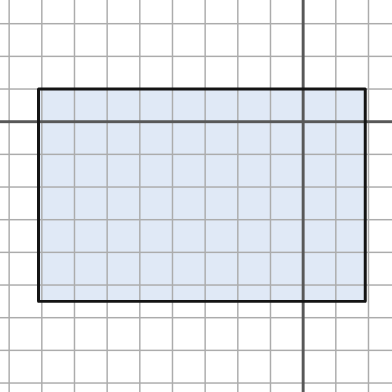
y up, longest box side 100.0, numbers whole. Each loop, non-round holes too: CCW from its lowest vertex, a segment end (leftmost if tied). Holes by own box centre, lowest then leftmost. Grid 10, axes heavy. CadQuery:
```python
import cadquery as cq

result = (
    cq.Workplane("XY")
    .moveTo(-81.0, -55.0)
    .lineTo(19.0, -55.0)
    .lineTo(19.0, 10.0)
    .lineTo(-81.0, 10.0)
    .close()
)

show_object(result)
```